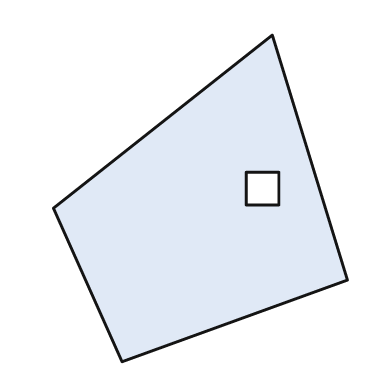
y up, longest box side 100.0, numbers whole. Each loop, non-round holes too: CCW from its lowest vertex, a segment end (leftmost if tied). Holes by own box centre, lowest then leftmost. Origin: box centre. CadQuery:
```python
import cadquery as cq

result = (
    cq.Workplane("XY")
    .moveTo(-24.0, -50.0)
    .lineTo(45.0, -25.0)
    .lineTo(22.0, 50.0)
    .lineTo(-45.0, -3.0)
    .close()
    .moveTo(14.0, -2.0)
    .lineTo(24.0, -2.0)
    .lineTo(24.0, 8.0)
    .lineTo(14.0, 8.0)
    .close()
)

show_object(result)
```